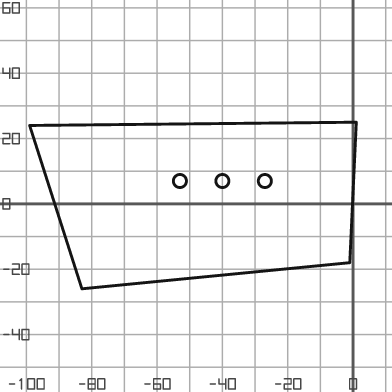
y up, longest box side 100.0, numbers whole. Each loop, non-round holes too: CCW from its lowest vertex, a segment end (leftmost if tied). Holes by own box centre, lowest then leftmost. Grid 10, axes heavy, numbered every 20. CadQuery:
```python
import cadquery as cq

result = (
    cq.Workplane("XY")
    .moveTo(-83.0, -26.0)
    .lineTo(-1.0, -18.0)
    .lineTo(1.0, 25.0)
    .lineTo(-99.0, 24.0)
    .close()
    .moveTo(-53.0, 7.0)
    .circle(2.0)
    .moveTo(-40.0, 7.0)
    .circle(2.0)
    .moveTo(-27.0, 7.0)
    .circle(2.0)
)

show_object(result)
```